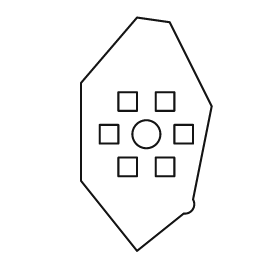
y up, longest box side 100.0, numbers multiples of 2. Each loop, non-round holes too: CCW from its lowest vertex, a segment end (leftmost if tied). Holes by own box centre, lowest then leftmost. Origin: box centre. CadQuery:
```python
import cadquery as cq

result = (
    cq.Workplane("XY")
    .moveTo(-4.0, -50.0)
    .lineTo(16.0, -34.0)
    .threePointArc((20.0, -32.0), (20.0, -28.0))
    .lineTo(28.0, 12.0)
    .lineTo(10.0, 48.0)
    .lineTo(-4.0, 50.0)
    .lineTo(-28.0, 22.0)
    .lineTo(-28.0, -20.0)
    .close()
    .moveTo(-12.0, -18.0)
    .lineTo(-4.0, -18.0)
    .lineTo(-4.0, -10.0)
    .lineTo(-12.0, -10.0)
    .close()
    .moveTo(4.0, -18.0)
    .lineTo(12.0, -18.0)
    .lineTo(12.0, -10.0)
    .lineTo(4.0, -10.0)
    .close()
    .moveTo(-20.0, -4.0)
    .lineTo(-12.0, -4.0)
    .lineTo(-12.0, 4.0)
    .lineTo(-20.0, 4.0)
    .close()
    .moveTo(0.0, 0.0)
    .circle(6.0)
    .moveTo(12.0, -4.0)
    .lineTo(20.0, -4.0)
    .lineTo(20.0, 4.0)
    .lineTo(12.0, 4.0)
    .close()
    .moveTo(-12.0, 10.0)
    .lineTo(-4.0, 10.0)
    .lineTo(-4.0, 18.0)
    .lineTo(-12.0, 18.0)
    .close()
    .moveTo(4.0, 10.0)
    .lineTo(12.0, 10.0)
    .lineTo(12.0, 18.0)
    .lineTo(4.0, 18.0)
    .close()
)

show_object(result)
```